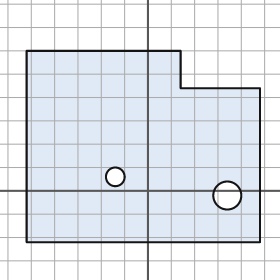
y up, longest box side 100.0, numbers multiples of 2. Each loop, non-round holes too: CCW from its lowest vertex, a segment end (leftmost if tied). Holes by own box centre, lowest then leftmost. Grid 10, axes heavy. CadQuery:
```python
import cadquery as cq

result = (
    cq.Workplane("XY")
    .moveTo(-52.0, -22.0)
    .lineTo(48.0, -22.0)
    .lineTo(48.0, 44.0)
    .lineTo(14.0, 44.0)
    .lineTo(14.0, 60.0)
    .lineTo(-52.0, 60.0)
    .close()
    .moveTo(34.0, -2.0)
    .circle(6.0)
    .moveTo(-14.0, 6.0)
    .circle(4.0)
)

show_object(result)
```